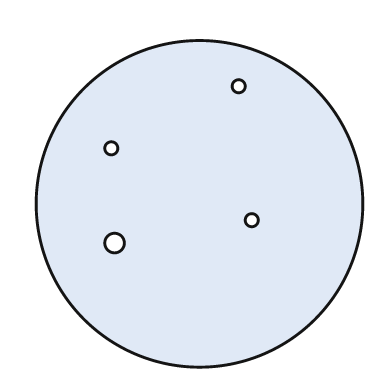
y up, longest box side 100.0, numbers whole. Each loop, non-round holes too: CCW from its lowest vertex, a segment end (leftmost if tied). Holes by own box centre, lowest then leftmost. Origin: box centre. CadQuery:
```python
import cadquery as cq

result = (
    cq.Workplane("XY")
    .moveTo(0.0, 0.0)
    .circle(50.0)
    .moveTo(-26.0, -12.0)
    .circle(3.0)
    .moveTo(16.0, -5.0)
    .circle(2.0)
    .moveTo(-27.0, 17.0)
    .circle(2.0)
    .moveTo(12.0, 36.0)
    .circle(2.0)
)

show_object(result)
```